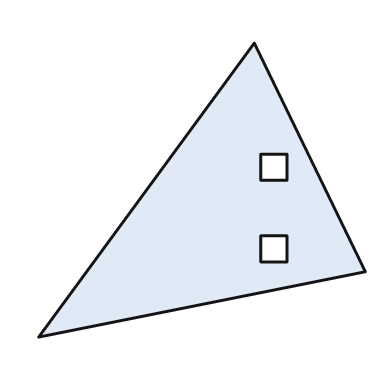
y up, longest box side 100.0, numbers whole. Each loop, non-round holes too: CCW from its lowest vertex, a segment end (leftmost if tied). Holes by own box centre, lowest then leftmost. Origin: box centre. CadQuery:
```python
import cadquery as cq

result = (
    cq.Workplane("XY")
    .moveTo(-50.0, -45.0)
    .lineTo(50.0, -25.0)
    .lineTo(16.0, 45.0)
    .close()
    .moveTo(18.0, -22.0)
    .lineTo(26.0, -22.0)
    .lineTo(26.0, -14.0)
    .lineTo(18.0, -14.0)
    .close()
    .moveTo(18.0, 3.0)
    .lineTo(26.0, 3.0)
    .lineTo(26.0, 11.0)
    .lineTo(18.0, 11.0)
    .close()
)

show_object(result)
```